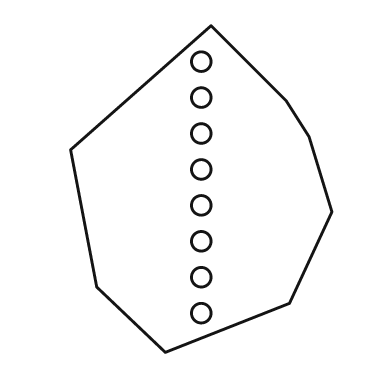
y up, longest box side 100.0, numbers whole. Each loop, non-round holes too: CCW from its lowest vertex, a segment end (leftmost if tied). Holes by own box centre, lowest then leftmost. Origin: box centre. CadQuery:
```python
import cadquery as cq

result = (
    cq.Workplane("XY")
    .moveTo(-11.0, -50.0)
    .lineTo(27.0, -35.0)
    .lineTo(40.0, -7.0)
    .lineTo(33.0, 16.0)
    .lineTo(26.0, 27.0)
    .lineTo(3.0, 50.0)
    .lineTo(-40.0, 12.0)
    .lineTo(-32.0, -30.0)
    .close()
    .moveTo(0.0, -38.0)
    .circle(3.0)
    .moveTo(0.0, -27.0)
    .circle(3.0)
    .moveTo(0.0, -16.0)
    .circle(3.0)
    .moveTo(0.0, -5.0)
    .circle(3.0)
    .moveTo(0.0, 6.0)
    .circle(3.0)
    .moveTo(0.0, 17.0)
    .circle(3.0)
    .moveTo(0.0, 28.0)
    .circle(3.0)
    .moveTo(0.0, 39.0)
    .circle(3.0)
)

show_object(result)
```